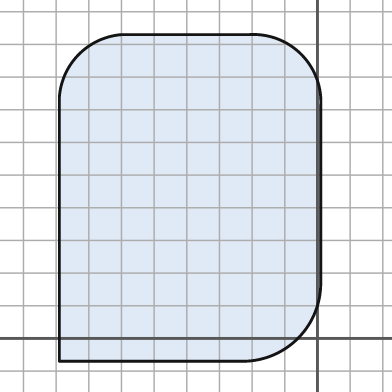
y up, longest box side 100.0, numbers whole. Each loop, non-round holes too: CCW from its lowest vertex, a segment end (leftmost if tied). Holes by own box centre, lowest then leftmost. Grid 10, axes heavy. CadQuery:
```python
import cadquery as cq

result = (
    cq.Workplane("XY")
    .moveTo(-79.0, -7.0)
    .lineTo(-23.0, -7.0)
    .threePointArc((-6.0, 0.0), (1.0, 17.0))
    .lineTo(1.0, 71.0)
    .threePointArc((-5.0, 87.0), (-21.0, 93.0))
    .lineTo(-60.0, 93.0)
    .threePointArc((-73.0, 87.0), (-79.0, 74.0))
    .close()
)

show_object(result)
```